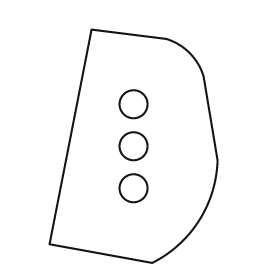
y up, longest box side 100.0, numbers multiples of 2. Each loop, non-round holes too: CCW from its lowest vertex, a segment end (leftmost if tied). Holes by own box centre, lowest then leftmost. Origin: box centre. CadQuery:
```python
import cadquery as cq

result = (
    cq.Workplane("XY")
    .moveTo(8.0, -50.0)
    .threePointArc((28.0, -32.0), (36.0, -6.0))
    .lineTo(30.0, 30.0)
    .threePointArc((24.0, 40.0), (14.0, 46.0))
    .lineTo(-18.0, 50.0)
    .lineTo(-36.0, -42.0)
    .close()
    .moveTo(0.0, -18.0)
    .circle(6.0)
    .moveTo(0.0, 0.0)
    .circle(6.0)
    .moveTo(0.0, 18.0)
    .circle(6.0)
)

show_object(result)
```